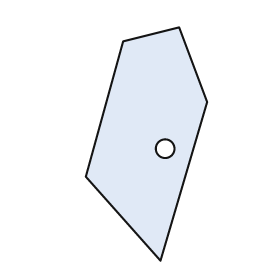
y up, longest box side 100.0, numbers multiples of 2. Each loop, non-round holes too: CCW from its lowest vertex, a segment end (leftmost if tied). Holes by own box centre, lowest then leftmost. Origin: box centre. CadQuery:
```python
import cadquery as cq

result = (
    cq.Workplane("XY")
    .moveTo(6.0, -50.0)
    .lineTo(26.0, 18.0)
    .lineTo(14.0, 50.0)
    .lineTo(-10.0, 44.0)
    .lineTo(-26.0, -14.0)
    .close()
    .moveTo(8.0, -2.0)
    .circle(4.0)
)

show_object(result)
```